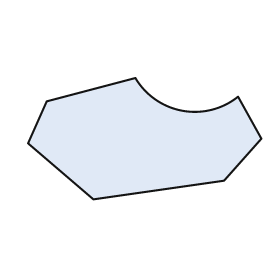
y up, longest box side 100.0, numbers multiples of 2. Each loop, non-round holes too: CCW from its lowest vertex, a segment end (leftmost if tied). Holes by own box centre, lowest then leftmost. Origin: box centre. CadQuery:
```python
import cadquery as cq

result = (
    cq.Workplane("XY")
    .moveTo(-22.0, -26.0)
    .lineTo(34.0, -18.0)
    .lineTo(50.0, 0.0)
    .lineTo(40.0, 18.0)
    .threePointArc((16.0, 12.0), (-4.0, 26.0))
    .lineTo(-42.0, 16.0)
    .lineTo(-50.0, -2.0)
    .close()
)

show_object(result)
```